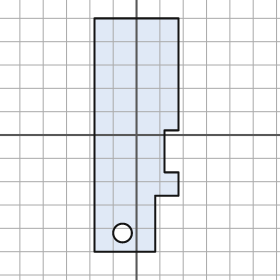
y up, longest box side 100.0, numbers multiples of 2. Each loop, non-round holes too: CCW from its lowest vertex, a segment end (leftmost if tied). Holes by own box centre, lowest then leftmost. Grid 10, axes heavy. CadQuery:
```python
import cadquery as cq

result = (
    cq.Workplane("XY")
    .moveTo(-18.0, -50.0)
    .lineTo(8.0, -50.0)
    .lineTo(8.0, -26.0)
    .lineTo(18.0, -26.0)
    .lineTo(18.0, -16.0)
    .lineTo(12.0, -16.0)
    .lineTo(12.0, 2.0)
    .lineTo(18.0, 2.0)
    .lineTo(18.0, 50.0)
    .lineTo(-18.0, 50.0)
    .close()
    .moveTo(-6.0, -42.0)
    .circle(4.0)
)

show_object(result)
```